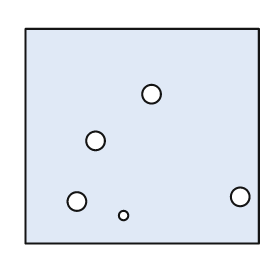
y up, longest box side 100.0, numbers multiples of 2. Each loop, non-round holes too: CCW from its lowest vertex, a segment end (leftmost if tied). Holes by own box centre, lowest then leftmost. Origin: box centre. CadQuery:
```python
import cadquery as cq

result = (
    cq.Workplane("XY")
    .moveTo(-50.0, -46.0)
    .lineTo(50.0, -46.0)
    .lineTo(50.0, 46.0)
    .lineTo(-50.0, 46.0)
    .close()
    .moveTo(-8.0, -34.0)
    .circle(2.0)
    .moveTo(-28.0, -28.0)
    .circle(4.0)
    .moveTo(42.0, -26.0)
    .circle(4.0)
    .moveTo(-20.0, -2.0)
    .circle(4.0)
    .moveTo(4.0, 18.0)
    .circle(4.0)
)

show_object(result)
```